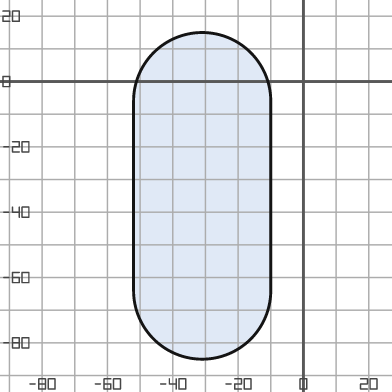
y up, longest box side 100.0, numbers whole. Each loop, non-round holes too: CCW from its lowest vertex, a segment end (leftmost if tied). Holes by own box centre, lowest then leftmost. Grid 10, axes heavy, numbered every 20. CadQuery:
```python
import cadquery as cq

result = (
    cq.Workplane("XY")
    .moveTo(-52.0, -64.0)
    .threePointArc((-31.0, -85.0), (-10.0, -64.0))
    .lineTo(-10.0, -6.0)
    .threePointArc((-31.0, 15.0), (-52.0, -6.0))
    .close()
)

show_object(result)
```